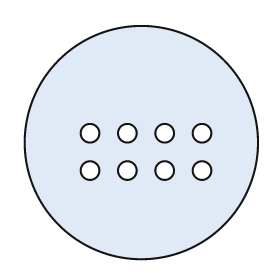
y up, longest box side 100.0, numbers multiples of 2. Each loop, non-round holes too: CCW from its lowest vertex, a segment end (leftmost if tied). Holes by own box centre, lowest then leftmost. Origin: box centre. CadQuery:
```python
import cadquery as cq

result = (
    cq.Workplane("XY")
    .moveTo(0.0, 0.0)
    .circle(50.0)
    .moveTo(-22.0, -12.0)
    .circle(4.0)
    .moveTo(-6.0, -12.0)
    .circle(4.0)
    .moveTo(10.0, -12.0)
    .circle(4.0)
    .moveTo(26.0, -12.0)
    .circle(4.0)
    .moveTo(-22.0, 4.0)
    .circle(4.0)
    .moveTo(-6.0, 4.0)
    .circle(4.0)
    .moveTo(10.0, 4.0)
    .circle(4.0)
    .moveTo(26.0, 4.0)
    .circle(4.0)
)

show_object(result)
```